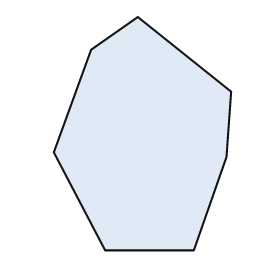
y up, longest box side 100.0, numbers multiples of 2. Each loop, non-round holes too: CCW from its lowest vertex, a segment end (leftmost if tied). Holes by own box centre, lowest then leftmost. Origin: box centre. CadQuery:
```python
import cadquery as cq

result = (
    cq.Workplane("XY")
    .moveTo(-16.0, -50.0)
    .lineTo(22.0, -50.0)
    .lineTo(36.0, -10.0)
    .lineTo(38.0, 18.0)
    .lineTo(-2.0, 50.0)
    .lineTo(-22.0, 36.0)
    .lineTo(-38.0, -8.0)
    .close()
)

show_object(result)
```